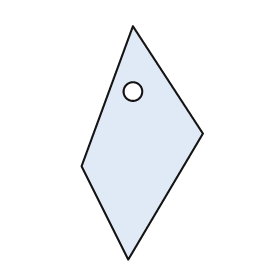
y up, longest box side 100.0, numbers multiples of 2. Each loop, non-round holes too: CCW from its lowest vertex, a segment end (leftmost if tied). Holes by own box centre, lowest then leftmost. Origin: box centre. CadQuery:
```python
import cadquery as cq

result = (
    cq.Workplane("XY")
    .moveTo(-6.0, -50.0)
    .lineTo(26.0, 4.0)
    .lineTo(-4.0, 50.0)
    .lineTo(-26.0, -10.0)
    .close()
    .moveTo(-4.0, 22.0)
    .circle(4.0)
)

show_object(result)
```